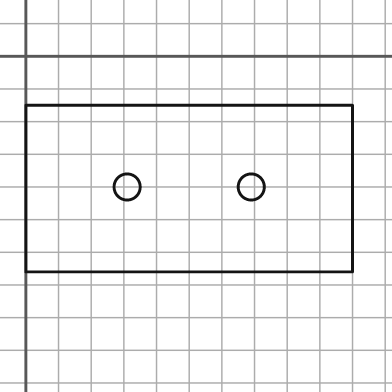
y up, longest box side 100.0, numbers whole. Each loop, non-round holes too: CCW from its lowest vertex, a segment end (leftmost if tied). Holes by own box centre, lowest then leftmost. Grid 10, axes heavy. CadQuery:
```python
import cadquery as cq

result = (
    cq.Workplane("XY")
    .moveTo(0.0, -66.0)
    .lineTo(100.0, -66.0)
    .lineTo(100.0, -15.0)
    .lineTo(0.0, -15.0)
    .close()
    .moveTo(31.0, -40.0)
    .circle(4.0)
    .moveTo(69.0, -40.0)
    .circle(4.0)
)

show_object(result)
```